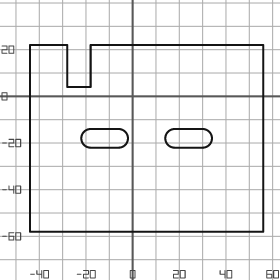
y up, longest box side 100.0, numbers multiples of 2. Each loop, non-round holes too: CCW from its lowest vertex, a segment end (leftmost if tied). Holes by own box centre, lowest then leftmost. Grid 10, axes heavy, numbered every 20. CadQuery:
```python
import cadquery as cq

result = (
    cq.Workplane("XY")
    .moveTo(-44.0, -58.0)
    .lineTo(56.0, -58.0)
    .lineTo(56.0, 22.0)
    .lineTo(-18.0, 22.0)
    .lineTo(-18.0, 4.0)
    .lineTo(-28.0, 4.0)
    .lineTo(-28.0, 22.0)
    .lineTo(-44.0, 22.0)
    .close()
    .moveTo(-18.0, -22.0)
    .lineTo(-6.0, -22.0)
    .threePointArc((-2.0, -18.0), (-6.0, -14.0))
    .lineTo(-18.0, -14.0)
    .threePointArc((-22.0, -18.0), (-18.0, -22.0))
    .close()
    .moveTo(18.0, -22.0)
    .lineTo(30.0, -22.0)
    .threePointArc((34.0, -18.0), (30.0, -14.0))
    .lineTo(18.0, -14.0)
    .threePointArc((14.0, -18.0), (18.0, -22.0))
    .close()
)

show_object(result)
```